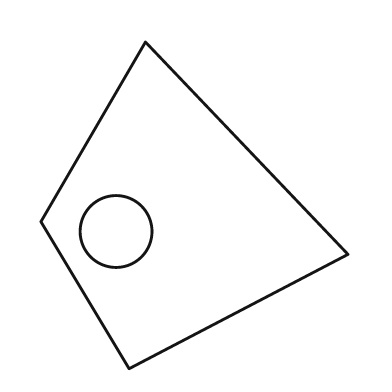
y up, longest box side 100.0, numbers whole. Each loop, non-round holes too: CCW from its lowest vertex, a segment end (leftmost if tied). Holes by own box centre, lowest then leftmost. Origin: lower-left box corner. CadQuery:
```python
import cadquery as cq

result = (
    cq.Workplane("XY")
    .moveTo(27.0, 0.0)
    .lineTo(94.0, 35.0)
    .lineTo(32.0, 100.0)
    .lineTo(0.0, 45.0)
    .close()
    .moveTo(23.0, 42.0)
    .circle(11.0)
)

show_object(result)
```